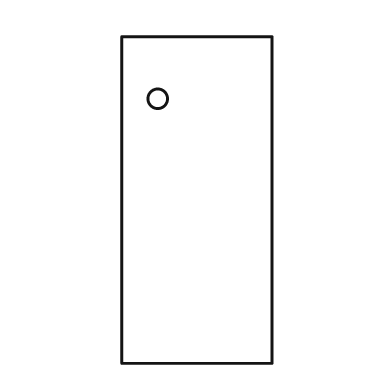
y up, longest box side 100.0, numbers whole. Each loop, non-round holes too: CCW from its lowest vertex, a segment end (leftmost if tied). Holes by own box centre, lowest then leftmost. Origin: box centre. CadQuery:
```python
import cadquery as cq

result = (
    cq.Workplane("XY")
    .moveTo(-23.0, -50.0)
    .lineTo(23.0, -50.0)
    .lineTo(23.0, 50.0)
    .lineTo(-23.0, 50.0)
    .close()
    .moveTo(-12.0, 31.0)
    .circle(3.0)
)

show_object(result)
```